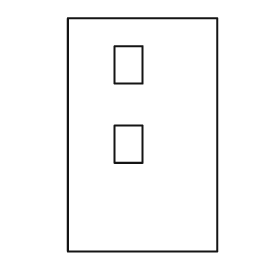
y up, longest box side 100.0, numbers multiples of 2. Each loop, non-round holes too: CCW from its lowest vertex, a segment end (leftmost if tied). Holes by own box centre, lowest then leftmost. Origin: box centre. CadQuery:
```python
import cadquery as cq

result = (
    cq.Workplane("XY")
    .moveTo(-32.0, -50.0)
    .lineTo(32.0, -50.0)
    .lineTo(32.0, 50.0)
    .lineTo(-32.0, 50.0)
    .close()
    .moveTo(-12.0, -12.0)
    .lineTo(0.0, -12.0)
    .lineTo(0.0, 4.0)
    .lineTo(-12.0, 4.0)
    .close()
    .moveTo(-12.0, 22.0)
    .lineTo(0.0, 22.0)
    .lineTo(0.0, 38.0)
    .lineTo(-12.0, 38.0)
    .close()
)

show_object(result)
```